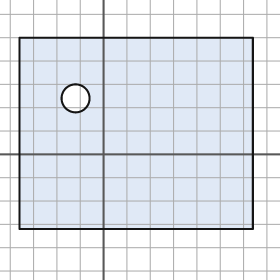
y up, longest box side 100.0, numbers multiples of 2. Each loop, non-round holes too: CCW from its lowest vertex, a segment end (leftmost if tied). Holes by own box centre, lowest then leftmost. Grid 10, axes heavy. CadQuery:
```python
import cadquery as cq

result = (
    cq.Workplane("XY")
    .moveTo(-36.0, -32.0)
    .lineTo(64.0, -32.0)
    .lineTo(64.0, 50.0)
    .lineTo(-36.0, 50.0)
    .close()
    .moveTo(-12.0, 24.0)
    .circle(6.0)
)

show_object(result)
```